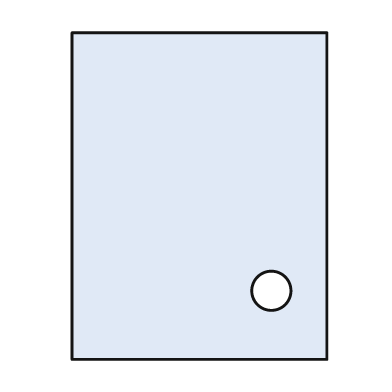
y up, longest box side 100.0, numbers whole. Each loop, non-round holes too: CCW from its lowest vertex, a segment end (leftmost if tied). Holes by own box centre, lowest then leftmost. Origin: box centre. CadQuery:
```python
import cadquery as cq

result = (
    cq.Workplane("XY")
    .moveTo(-39.0, -50.0)
    .lineTo(39.0, -50.0)
    .lineTo(39.0, 50.0)
    .lineTo(-39.0, 50.0)
    .close()
    .moveTo(22.0, -29.0)
    .circle(6.0)
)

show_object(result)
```